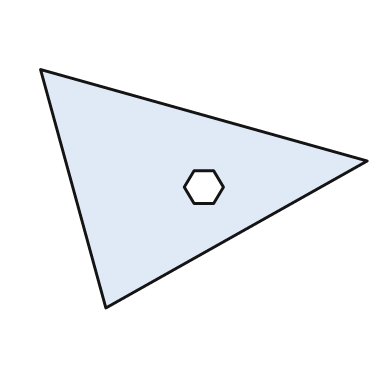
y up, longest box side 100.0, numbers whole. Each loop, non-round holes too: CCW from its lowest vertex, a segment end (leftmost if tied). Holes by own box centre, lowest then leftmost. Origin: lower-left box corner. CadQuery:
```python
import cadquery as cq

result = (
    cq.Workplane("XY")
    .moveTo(20.0, 0.0)
    .lineTo(100.0, 45.0)
    .lineTo(0.0, 73.0)
    .close()
    .moveTo(47.0, 32.0)
    .lineTo(53.0, 32.0)
    .lineTo(56.0, 37.0)
    .lineTo(53.0, 42.0)
    .lineTo(47.0, 42.0)
    .lineTo(44.0, 37.0)
    .close()
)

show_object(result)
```